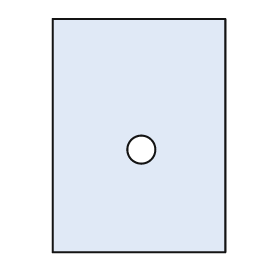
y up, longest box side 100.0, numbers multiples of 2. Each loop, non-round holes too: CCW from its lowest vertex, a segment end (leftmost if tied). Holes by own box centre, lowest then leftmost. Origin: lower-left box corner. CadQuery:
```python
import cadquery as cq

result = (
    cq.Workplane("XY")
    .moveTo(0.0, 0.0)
    .lineTo(74.0, 0.0)
    .lineTo(74.0, 100.0)
    .lineTo(0.0, 100.0)
    .close()
    .moveTo(38.0, 44.0)
    .circle(6.0)
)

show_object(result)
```